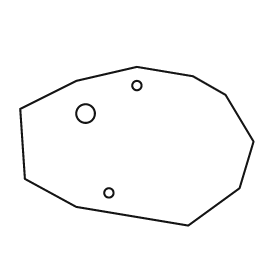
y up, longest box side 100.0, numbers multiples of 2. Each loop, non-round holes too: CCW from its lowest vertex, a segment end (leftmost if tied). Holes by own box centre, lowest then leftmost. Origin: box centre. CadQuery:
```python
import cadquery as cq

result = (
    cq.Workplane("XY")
    .moveTo(22.0, -34.0)
    .lineTo(44.0, -18.0)
    .lineTo(50.0, 2.0)
    .lineTo(38.0, 22.0)
    .lineTo(24.0, 30.0)
    .lineTo(0.0, 34.0)
    .lineTo(-26.0, 28.0)
    .lineTo(-50.0, 16.0)
    .lineTo(-48.0, -14.0)
    .lineTo(-26.0, -26.0)
    .close()
    .moveTo(-12.0, -20.0)
    .circle(2.0)
    .moveTo(-22.0, 14.0)
    .circle(4.0)
    .moveTo(0.0, 26.0)
    .circle(2.0)
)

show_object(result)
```